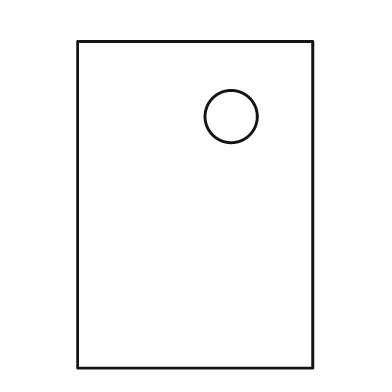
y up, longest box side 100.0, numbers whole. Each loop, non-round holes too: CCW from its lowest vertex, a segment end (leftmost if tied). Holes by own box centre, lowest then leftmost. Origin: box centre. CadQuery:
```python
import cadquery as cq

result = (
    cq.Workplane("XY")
    .moveTo(-36.0, -50.0)
    .lineTo(36.0, -50.0)
    .lineTo(36.0, 50.0)
    .lineTo(-36.0, 50.0)
    .close()
    .moveTo(11.0, 27.0)
    .circle(8.0)
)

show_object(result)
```